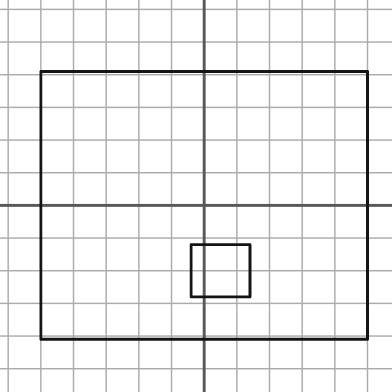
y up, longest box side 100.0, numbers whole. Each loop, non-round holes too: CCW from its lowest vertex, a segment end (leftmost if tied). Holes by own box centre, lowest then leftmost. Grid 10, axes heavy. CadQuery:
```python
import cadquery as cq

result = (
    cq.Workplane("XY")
    .moveTo(-50.0, -41.0)
    .lineTo(50.0, -41.0)
    .lineTo(50.0, 41.0)
    .lineTo(-50.0, 41.0)
    .close()
    .moveTo(-4.0, -28.0)
    .lineTo(14.0, -28.0)
    .lineTo(14.0, -12.0)
    .lineTo(-4.0, -12.0)
    .close()
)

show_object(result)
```